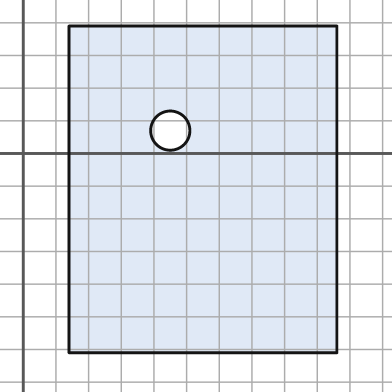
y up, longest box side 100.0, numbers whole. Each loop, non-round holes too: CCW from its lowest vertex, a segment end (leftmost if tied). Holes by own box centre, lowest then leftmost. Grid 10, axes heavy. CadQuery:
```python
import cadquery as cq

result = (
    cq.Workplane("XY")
    .moveTo(14.0, -61.0)
    .lineTo(96.0, -61.0)
    .lineTo(96.0, 39.0)
    .lineTo(14.0, 39.0)
    .close()
    .moveTo(45.0, 7.0)
    .circle(6.0)
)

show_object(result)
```